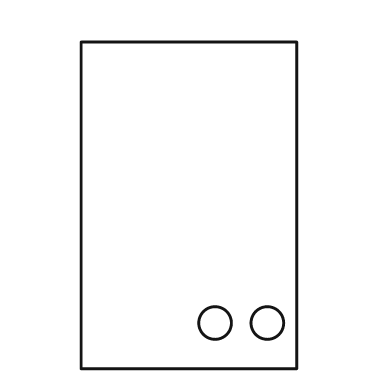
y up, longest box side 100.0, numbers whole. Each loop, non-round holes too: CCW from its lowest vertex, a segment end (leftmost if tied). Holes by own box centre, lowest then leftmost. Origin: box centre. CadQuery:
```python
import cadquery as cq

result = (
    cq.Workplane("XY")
    .moveTo(-33.0, -50.0)
    .lineTo(33.0, -50.0)
    .lineTo(33.0, 50.0)
    .lineTo(-33.0, 50.0)
    .close()
    .moveTo(8.0, -36.0)
    .circle(5.0)
    .moveTo(24.0, -36.0)
    .circle(5.0)
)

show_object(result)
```